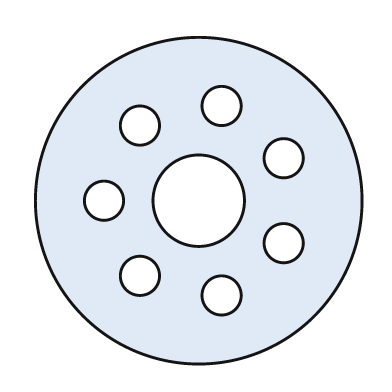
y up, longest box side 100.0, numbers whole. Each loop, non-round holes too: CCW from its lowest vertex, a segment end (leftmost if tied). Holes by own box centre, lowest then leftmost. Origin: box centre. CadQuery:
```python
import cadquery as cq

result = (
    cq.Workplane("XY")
    .moveTo(0.0, 0.0)
    .circle(50.0)
    .moveTo(7.0, -29.0)
    .circle(6.0)
    .moveTo(-18.0, -23.0)
    .circle(6.0)
    .moveTo(26.0, -13.0)
    .circle(6.0)
    .moveTo(-29.0, 0.0)
    .circle(6.0)
    .moveTo(0.0, 0.0)
    .circle(14.0)
    .moveTo(26.0, 13.0)
    .circle(6.0)
    .moveTo(-18.0, 23.0)
    .circle(6.0)
    .moveTo(7.0, 29.0)
    .circle(6.0)
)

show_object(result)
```